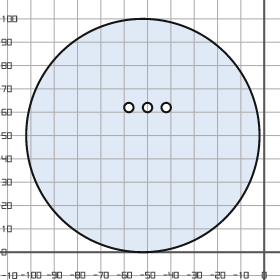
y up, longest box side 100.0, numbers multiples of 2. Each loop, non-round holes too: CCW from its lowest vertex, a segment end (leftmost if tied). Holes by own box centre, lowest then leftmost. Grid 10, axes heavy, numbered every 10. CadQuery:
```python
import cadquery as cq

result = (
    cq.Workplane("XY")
    .moveTo(-52.0, 50.0)
    .circle(50.0)
    .moveTo(-58.0, 62.0)
    .circle(2.0)
    .moveTo(-50.0, 62.0)
    .circle(2.0)
    .moveTo(-42.0, 62.0)
    .circle(2.0)
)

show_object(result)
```